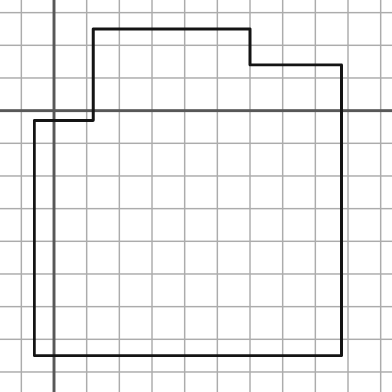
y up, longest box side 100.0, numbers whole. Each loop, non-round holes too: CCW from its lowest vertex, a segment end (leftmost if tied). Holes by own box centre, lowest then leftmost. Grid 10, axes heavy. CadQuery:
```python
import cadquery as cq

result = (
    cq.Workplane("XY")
    .moveTo(-6.0, -75.0)
    .lineTo(88.0, -75.0)
    .lineTo(88.0, 14.0)
    .lineTo(60.0, 14.0)
    .lineTo(60.0, 25.0)
    .lineTo(12.0, 25.0)
    .lineTo(12.0, -3.0)
    .lineTo(-6.0, -3.0)
    .close()
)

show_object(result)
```